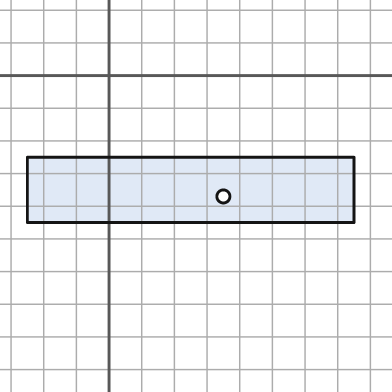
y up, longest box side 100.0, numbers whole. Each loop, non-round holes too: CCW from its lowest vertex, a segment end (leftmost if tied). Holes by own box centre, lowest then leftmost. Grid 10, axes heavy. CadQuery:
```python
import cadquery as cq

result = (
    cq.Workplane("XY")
    .moveTo(-25.0, -45.0)
    .lineTo(75.0, -45.0)
    .lineTo(75.0, -25.0)
    .lineTo(-25.0, -25.0)
    .close()
    .moveTo(35.0, -37.0)
    .circle(2.0)
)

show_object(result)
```